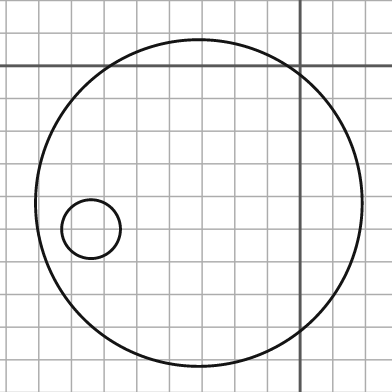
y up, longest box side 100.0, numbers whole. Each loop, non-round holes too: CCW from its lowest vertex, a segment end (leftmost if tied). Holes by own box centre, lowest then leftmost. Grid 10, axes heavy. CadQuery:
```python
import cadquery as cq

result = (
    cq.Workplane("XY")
    .moveTo(-31.0, -42.0)
    .circle(50.0)
    .moveTo(-64.0, -50.0)
    .circle(9.0)
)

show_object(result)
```